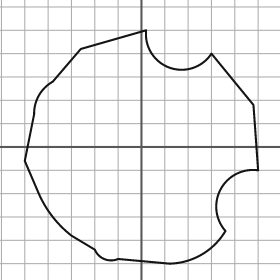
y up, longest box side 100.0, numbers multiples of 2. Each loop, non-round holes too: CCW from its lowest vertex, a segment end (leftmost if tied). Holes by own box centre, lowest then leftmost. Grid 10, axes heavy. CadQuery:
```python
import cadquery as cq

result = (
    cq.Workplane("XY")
    .moveTo(12.0, -50.0)
    .threePointArc((26.0, -46.0), (36.0, -36.0))
    .threePointArc((34.0, -18.0), (50.0, -10.0))
    .lineTo(48.0, 18.0)
    .lineTo(30.0, 40.0)
    .threePointArc((12.0, 34.0), (2.0, 50.0))
    .lineTo(-26.0, 42.0)
    .lineTo(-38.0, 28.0)
    .threePointArc((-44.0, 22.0), (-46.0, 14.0))
    .lineTo(-50.0, -6.0)
    .lineTo(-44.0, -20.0)
    .threePointArc((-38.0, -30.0), (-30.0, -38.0))
    .lineTo(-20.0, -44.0)
    .threePointArc((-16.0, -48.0), (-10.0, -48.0))
    .close()
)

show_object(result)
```